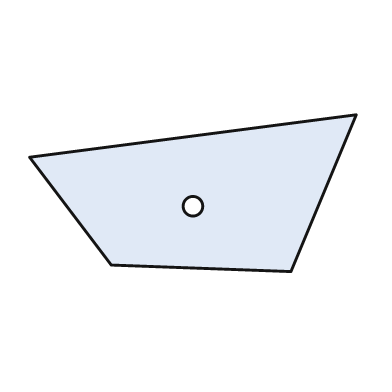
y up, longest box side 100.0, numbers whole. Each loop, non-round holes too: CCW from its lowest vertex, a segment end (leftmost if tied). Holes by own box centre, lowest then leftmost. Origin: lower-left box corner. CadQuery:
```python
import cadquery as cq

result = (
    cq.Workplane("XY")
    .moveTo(80.0, 0.0)
    .lineTo(100.0, 48.0)
    .lineTo(0.0, 35.0)
    .lineTo(25.0, 2.0)
    .close()
    .moveTo(50.0, 20.0)
    .circle(3.0)
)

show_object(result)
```